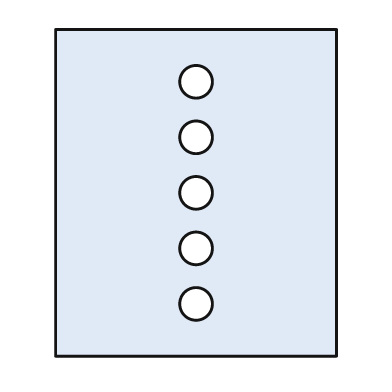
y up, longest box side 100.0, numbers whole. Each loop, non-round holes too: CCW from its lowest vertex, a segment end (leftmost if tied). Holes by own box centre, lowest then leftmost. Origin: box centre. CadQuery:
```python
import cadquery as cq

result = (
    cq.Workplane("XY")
    .moveTo(-43.0, -50.0)
    .lineTo(43.0, -50.0)
    .lineTo(43.0, 50.0)
    .lineTo(-43.0, 50.0)
    .close()
    .moveTo(0.0, -34.0)
    .circle(5.0)
    .moveTo(0.0, -17.0)
    .circle(5.0)
    .moveTo(0.0, 0.0)
    .circle(5.0)
    .moveTo(0.0, 17.0)
    .circle(5.0)
    .moveTo(0.0, 34.0)
    .circle(5.0)
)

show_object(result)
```